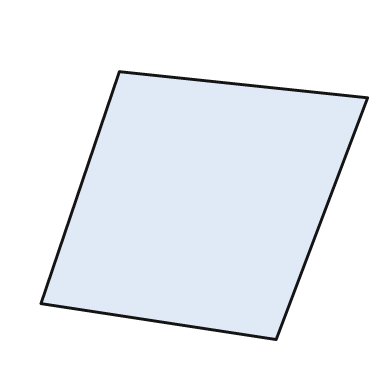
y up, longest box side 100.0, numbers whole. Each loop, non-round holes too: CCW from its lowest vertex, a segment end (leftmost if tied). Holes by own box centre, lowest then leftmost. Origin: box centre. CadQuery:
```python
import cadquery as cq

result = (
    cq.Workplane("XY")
    .moveTo(22.0, -41.0)
    .lineTo(50.0, 33.0)
    .lineTo(-26.0, 41.0)
    .lineTo(-50.0, -30.0)
    .close()
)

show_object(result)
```